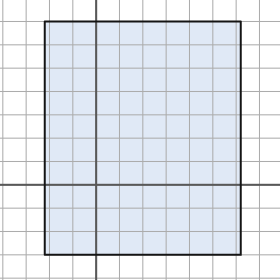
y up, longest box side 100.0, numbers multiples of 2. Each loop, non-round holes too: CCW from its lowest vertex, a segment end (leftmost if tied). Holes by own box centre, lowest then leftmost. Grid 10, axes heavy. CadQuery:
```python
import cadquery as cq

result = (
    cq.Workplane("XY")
    .moveTo(-22.0, -30.0)
    .lineTo(62.0, -30.0)
    .lineTo(62.0, 70.0)
    .lineTo(-22.0, 70.0)
    .close()
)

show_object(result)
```